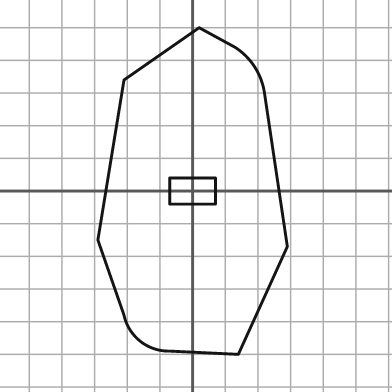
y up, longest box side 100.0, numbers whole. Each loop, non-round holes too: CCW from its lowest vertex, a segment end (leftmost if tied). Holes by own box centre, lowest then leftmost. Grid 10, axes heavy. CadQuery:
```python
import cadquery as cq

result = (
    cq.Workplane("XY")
    .moveTo(14.0, -50.0)
    .lineTo(29.0, -17.0)
    .lineTo(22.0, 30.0)
    .threePointArc((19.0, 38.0), (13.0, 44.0))
    .lineTo(2.0, 50.0)
    .lineTo(-21.0, 34.0)
    .lineTo(-29.0, -15.0)
    .lineTo(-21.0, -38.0)
    .threePointArc((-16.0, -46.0), (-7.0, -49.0))
    .close()
    .moveTo(-7.0, -4.0)
    .lineTo(7.0, -4.0)
    .lineTo(7.0, 4.0)
    .lineTo(-7.0, 4.0)
    .close()
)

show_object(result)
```